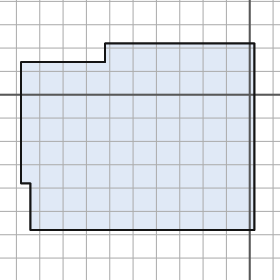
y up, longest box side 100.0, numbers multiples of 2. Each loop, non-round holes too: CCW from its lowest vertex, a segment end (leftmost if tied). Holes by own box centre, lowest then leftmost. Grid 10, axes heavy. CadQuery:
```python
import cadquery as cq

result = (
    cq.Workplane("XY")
    .moveTo(-94.0, -58.0)
    .lineTo(2.0, -58.0)
    .lineTo(2.0, 22.0)
    .lineTo(-62.0, 22.0)
    .lineTo(-62.0, 14.0)
    .lineTo(-98.0, 14.0)
    .lineTo(-98.0, -38.0)
    .lineTo(-94.0, -38.0)
    .close()
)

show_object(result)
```